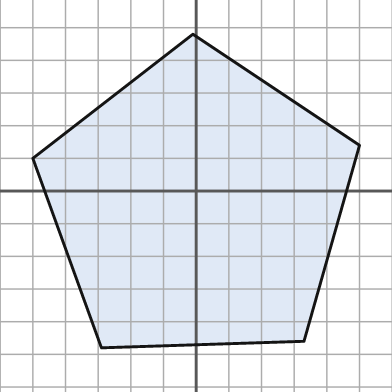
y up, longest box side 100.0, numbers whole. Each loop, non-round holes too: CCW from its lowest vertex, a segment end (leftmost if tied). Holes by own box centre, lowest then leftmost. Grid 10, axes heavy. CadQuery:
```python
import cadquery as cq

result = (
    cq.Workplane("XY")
    .moveTo(-29.0, -48.0)
    .lineTo(33.0, -46.0)
    .lineTo(50.0, 14.0)
    .lineTo(-1.0, 48.0)
    .lineTo(-50.0, 10.0)
    .close()
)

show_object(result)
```